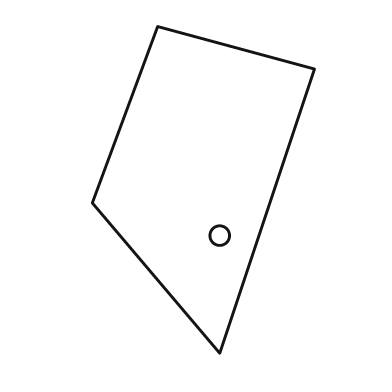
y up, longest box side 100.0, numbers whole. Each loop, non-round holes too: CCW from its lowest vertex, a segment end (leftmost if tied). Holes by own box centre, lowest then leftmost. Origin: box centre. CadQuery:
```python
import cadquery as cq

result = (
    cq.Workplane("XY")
    .moveTo(5.0, -50.0)
    .lineTo(34.0, 37.0)
    .lineTo(-14.0, 50.0)
    .lineTo(-34.0, -4.0)
    .close()
    .moveTo(5.0, -14.0)
    .circle(3.0)
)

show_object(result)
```